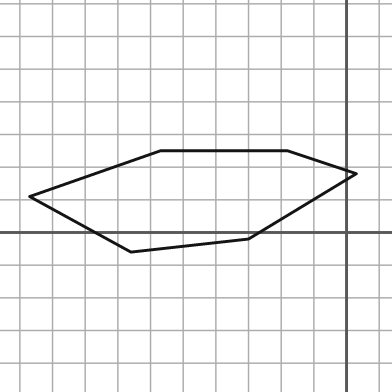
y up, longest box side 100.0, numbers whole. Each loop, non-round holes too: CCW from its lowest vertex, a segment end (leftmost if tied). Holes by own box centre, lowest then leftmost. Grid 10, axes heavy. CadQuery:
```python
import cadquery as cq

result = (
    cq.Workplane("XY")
    .moveTo(-66.0, -6.0)
    .lineTo(-30.0, -2.0)
    .lineTo(3.0, 18.0)
    .lineTo(-18.0, 25.0)
    .lineTo(-57.0, 25.0)
    .lineTo(-97.0, 11.0)
    .close()
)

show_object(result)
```